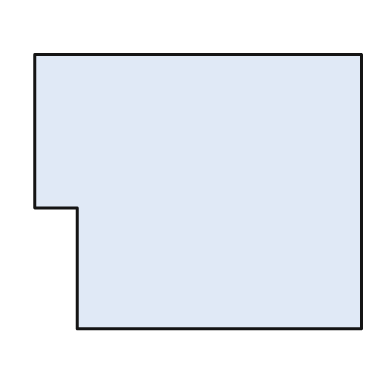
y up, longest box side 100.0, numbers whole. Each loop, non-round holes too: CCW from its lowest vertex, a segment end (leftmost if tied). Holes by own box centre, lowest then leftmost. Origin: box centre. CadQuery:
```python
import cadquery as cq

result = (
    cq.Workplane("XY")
    .moveTo(-37.0, -42.0)
    .lineTo(50.0, -42.0)
    .lineTo(50.0, 42.0)
    .lineTo(-50.0, 42.0)
    .lineTo(-50.0, -5.0)
    .lineTo(-37.0, -5.0)
    .close()
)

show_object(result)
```